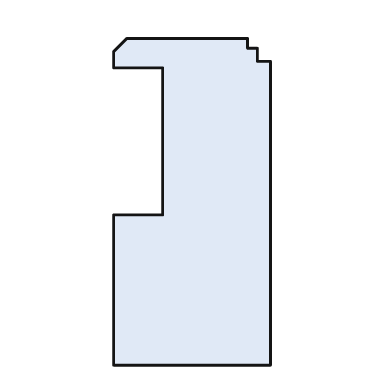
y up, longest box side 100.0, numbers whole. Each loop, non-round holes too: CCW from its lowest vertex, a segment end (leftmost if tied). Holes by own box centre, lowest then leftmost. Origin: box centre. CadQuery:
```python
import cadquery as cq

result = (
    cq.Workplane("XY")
    .moveTo(-24.0, -50.0)
    .lineTo(24.0, -50.0)
    .lineTo(24.0, 43.0)
    .lineTo(20.0, 43.0)
    .lineTo(20.0, 47.0)
    .lineTo(17.0, 47.0)
    .lineTo(17.0, 50.0)
    .lineTo(-20.0, 50.0)
    .lineTo(-24.0, 46.0)
    .lineTo(-24.0, 41.0)
    .lineTo(-9.0, 41.0)
    .lineTo(-9.0, -4.0)
    .lineTo(-24.0, -4.0)
    .close()
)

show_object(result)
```